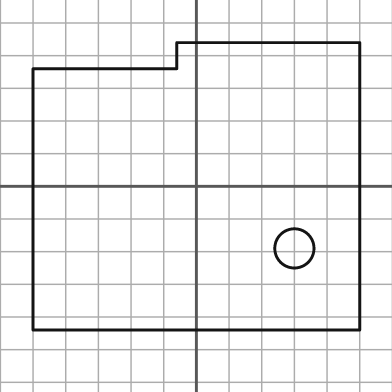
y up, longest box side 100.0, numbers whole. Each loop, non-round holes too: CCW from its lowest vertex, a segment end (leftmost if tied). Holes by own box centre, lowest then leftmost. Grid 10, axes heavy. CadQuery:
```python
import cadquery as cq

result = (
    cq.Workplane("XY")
    .moveTo(-50.0, -44.0)
    .lineTo(50.0, -44.0)
    .lineTo(50.0, 44.0)
    .lineTo(-6.0, 44.0)
    .lineTo(-6.0, 36.0)
    .lineTo(-50.0, 36.0)
    .close()
    .moveTo(30.0, -19.0)
    .circle(6.0)
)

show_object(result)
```